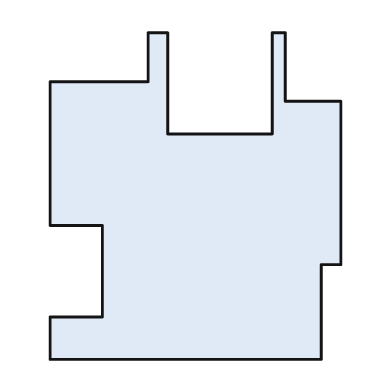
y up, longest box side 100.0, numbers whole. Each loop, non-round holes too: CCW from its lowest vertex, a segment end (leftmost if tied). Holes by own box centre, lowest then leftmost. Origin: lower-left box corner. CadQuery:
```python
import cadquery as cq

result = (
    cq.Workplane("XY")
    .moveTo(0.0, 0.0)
    .lineTo(83.0, 0.0)
    .lineTo(83.0, 29.0)
    .lineTo(89.0, 29.0)
    .lineTo(89.0, 79.0)
    .lineTo(72.0, 79.0)
    .lineTo(72.0, 100.0)
    .lineTo(68.0, 100.0)
    .lineTo(68.0, 69.0)
    .lineTo(36.0, 69.0)
    .lineTo(36.0, 100.0)
    .lineTo(30.0, 100.0)
    .lineTo(30.0, 85.0)
    .lineTo(0.0, 85.0)
    .lineTo(0.0, 41.0)
    .lineTo(16.0, 41.0)
    .lineTo(16.0, 13.0)
    .lineTo(0.0, 13.0)
    .close()
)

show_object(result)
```